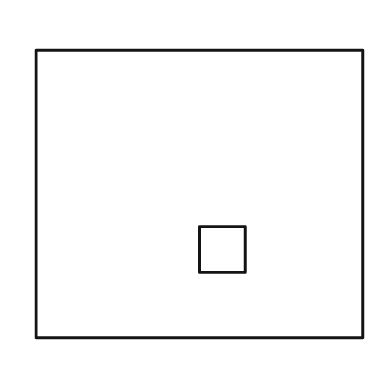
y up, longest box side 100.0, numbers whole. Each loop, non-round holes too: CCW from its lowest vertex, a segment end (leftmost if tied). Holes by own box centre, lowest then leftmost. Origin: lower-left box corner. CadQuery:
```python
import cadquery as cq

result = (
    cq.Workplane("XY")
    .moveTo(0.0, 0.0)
    .lineTo(100.0, 0.0)
    .lineTo(100.0, 88.0)
    .lineTo(0.0, 88.0)
    .close()
    .moveTo(50.0, 20.0)
    .lineTo(64.0, 20.0)
    .lineTo(64.0, 34.0)
    .lineTo(50.0, 34.0)
    .close()
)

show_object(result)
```